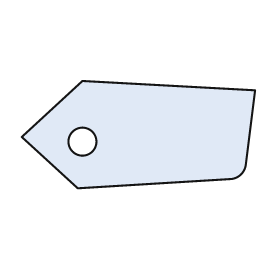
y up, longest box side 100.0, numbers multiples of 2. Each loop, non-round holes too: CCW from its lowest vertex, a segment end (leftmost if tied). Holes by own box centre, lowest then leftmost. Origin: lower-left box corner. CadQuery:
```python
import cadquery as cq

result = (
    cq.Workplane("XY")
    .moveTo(24.0, 0.0)
    .lineTo(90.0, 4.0)
    .threePointArc((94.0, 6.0), (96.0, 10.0))
    .lineTo(100.0, 42.0)
    .lineTo(26.0, 46.0)
    .lineTo(0.0, 22.0)
    .close()
    .moveTo(26.0, 20.0)
    .circle(6.0)
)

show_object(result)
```